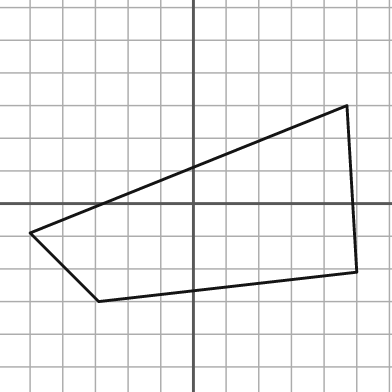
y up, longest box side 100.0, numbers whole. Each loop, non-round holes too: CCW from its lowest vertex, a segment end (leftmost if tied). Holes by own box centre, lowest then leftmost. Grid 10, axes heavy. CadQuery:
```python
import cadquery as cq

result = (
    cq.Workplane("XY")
    .moveTo(-29.0, -30.0)
    .lineTo(50.0, -21.0)
    .lineTo(47.0, 30.0)
    .lineTo(-50.0, -9.0)
    .close()
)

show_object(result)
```